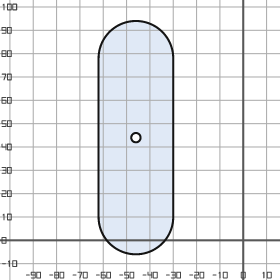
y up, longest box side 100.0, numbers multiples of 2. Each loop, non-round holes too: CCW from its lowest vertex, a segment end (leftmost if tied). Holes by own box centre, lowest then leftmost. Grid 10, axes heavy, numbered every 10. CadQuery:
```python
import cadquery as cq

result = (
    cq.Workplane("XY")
    .moveTo(-62.0, 10.0)
    .threePointArc((-46.0, -6.0), (-30.0, 10.0))
    .lineTo(-30.0, 78.0)
    .threePointArc((-46.0, 94.0), (-62.0, 78.0))
    .close()
    .moveTo(-46.0, 44.0)
    .circle(2.0)
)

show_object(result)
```